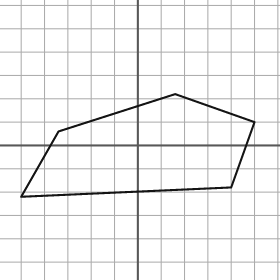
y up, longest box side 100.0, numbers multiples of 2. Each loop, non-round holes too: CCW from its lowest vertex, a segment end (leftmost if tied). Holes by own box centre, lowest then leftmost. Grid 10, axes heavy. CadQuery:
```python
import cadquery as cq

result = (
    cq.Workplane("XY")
    .moveTo(-50.0, -22.0)
    .lineTo(40.0, -18.0)
    .lineTo(50.0, 10.0)
    .lineTo(16.0, 22.0)
    .lineTo(-34.0, 6.0)
    .close()
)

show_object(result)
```